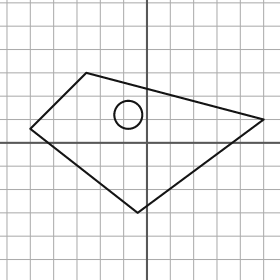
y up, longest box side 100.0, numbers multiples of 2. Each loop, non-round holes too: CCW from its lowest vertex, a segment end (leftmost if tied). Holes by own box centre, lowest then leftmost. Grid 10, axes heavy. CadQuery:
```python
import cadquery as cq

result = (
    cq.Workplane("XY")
    .moveTo(-4.0, -30.0)
    .lineTo(50.0, 10.0)
    .lineTo(-26.0, 30.0)
    .lineTo(-50.0, 6.0)
    .close()
    .moveTo(-8.0, 12.0)
    .circle(6.0)
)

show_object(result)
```